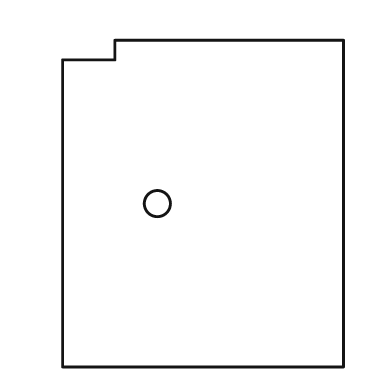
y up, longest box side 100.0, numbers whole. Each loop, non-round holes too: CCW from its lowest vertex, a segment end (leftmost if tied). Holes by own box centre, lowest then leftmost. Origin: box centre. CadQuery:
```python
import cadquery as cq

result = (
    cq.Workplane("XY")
    .moveTo(-43.0, -50.0)
    .lineTo(43.0, -50.0)
    .lineTo(43.0, 50.0)
    .lineTo(-27.0, 50.0)
    .lineTo(-27.0, 44.0)
    .lineTo(-43.0, 44.0)
    .close()
    .moveTo(-14.0, 0.0)
    .circle(4.0)
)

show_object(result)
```